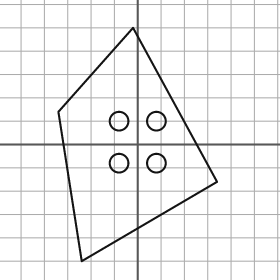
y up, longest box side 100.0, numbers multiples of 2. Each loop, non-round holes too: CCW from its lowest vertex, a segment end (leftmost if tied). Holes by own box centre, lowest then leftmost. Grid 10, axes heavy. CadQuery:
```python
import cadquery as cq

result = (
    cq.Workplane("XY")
    .moveTo(-24.0, -50.0)
    .lineTo(34.0, -16.0)
    .lineTo(-2.0, 50.0)
    .lineTo(-34.0, 14.0)
    .close()
    .moveTo(-8.0, -8.0)
    .circle(4.0)
    .moveTo(8.0, -8.0)
    .circle(4.0)
    .moveTo(-8.0, 10.0)
    .circle(4.0)
    .moveTo(8.0, 10.0)
    .circle(4.0)
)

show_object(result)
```